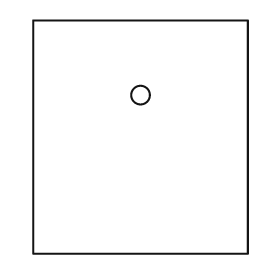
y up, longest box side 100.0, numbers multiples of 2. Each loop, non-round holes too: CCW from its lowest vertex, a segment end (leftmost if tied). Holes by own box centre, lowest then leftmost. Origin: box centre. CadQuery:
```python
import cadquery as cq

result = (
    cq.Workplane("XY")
    .moveTo(-46.0, -50.0)
    .lineTo(46.0, -50.0)
    .lineTo(46.0, 50.0)
    .lineTo(-46.0, 50.0)
    .close()
    .moveTo(0.0, 18.0)
    .circle(4.0)
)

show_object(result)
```